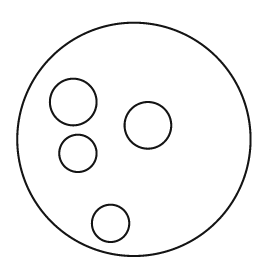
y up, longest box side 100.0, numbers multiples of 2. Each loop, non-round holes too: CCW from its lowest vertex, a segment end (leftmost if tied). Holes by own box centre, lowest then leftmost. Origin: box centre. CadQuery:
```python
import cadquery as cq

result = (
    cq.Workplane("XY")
    .moveTo(0.0, 0.0)
    .circle(50.0)
    .moveTo(-10.0, -36.0)
    .circle(8.0)
    .moveTo(-24.0, -6.0)
    .circle(8.0)
    .moveTo(6.0, 6.0)
    .circle(10.0)
    .moveTo(-26.0, 16.0)
    .circle(10.0)
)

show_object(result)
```